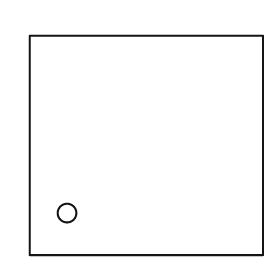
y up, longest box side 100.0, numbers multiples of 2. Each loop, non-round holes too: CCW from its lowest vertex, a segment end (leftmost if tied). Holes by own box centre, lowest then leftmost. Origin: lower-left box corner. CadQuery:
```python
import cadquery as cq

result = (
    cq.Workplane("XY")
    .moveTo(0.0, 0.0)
    .lineTo(100.0, 0.0)
    .lineTo(100.0, 94.0)
    .lineTo(0.0, 94.0)
    .close()
    .moveTo(16.0, 18.0)
    .circle(4.0)
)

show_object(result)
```